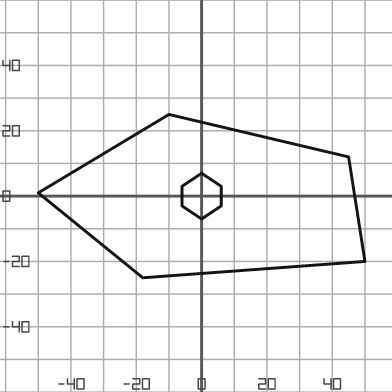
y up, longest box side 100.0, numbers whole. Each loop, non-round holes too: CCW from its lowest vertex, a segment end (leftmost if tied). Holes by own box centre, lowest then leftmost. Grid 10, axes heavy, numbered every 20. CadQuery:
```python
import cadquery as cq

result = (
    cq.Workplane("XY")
    .moveTo(-18.0, -25.0)
    .lineTo(50.0, -20.0)
    .lineTo(45.0, 12.0)
    .lineTo(-10.0, 25.0)
    .lineTo(-50.0, 1.0)
    .close()
    .moveTo(0.0, -7.0)
    .lineTo(6.0, -3.0)
    .lineTo(6.0, 3.0)
    .lineTo(0.0, 7.0)
    .lineTo(-6.0, 3.0)
    .lineTo(-6.0, -3.0)
    .close()
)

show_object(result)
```